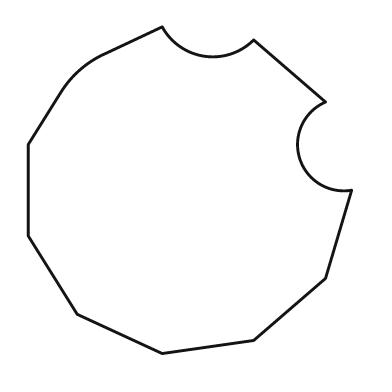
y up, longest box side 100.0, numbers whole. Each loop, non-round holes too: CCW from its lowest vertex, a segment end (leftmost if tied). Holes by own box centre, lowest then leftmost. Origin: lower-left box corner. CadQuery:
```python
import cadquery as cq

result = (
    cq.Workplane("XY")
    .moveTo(41.0, 0.0)
    .lineTo(69.0, 4.0)
    .lineTo(91.0, 23.0)
    .lineTo(99.0, 50.0)
    .threePointArc((83.0, 60.0), (91.0, 77.0))
    .lineTo(69.0, 96.0)
    .threePointArc((54.0, 91.0), (41.0, 100.0))
    .lineTo(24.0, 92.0)
    .threePointArc((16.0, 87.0), (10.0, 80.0))
    .lineTo(0.0, 64.0)
    .lineTo(0.0, 36.0)
    .lineTo(15.0, 12.0)
    .close()
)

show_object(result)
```